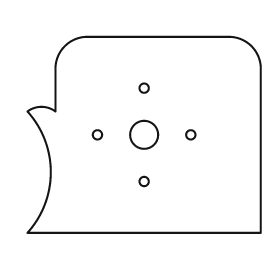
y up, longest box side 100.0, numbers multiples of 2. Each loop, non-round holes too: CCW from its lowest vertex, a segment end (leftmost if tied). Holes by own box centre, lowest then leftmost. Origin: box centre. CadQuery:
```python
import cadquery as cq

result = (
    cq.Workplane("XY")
    .moveTo(-50.0, -42.0)
    .lineTo(50.0, -42.0)
    .lineTo(50.0, 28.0)
    .threePointArc((46.0, 38.0), (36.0, 42.0))
    .lineTo(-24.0, 42.0)
    .threePointArc((-34.0, 38.0), (-38.0, 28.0))
    .lineTo(-38.0, 10.0)
    .threePointArc((-44.0, 12.0), (-50.0, 10.0))
    .threePointArc((-40.0, -16.0), (-50.0, -42.0))
    .close()
    .moveTo(0.0, -20.0)
    .circle(2.0)
    .moveTo(-20.0, 0.0)
    .circle(2.0)
    .moveTo(0.0, 0.0)
    .circle(6.0)
    .moveTo(20.0, 0.0)
    .circle(2.0)
    .moveTo(0.0, 20.0)
    .circle(2.0)
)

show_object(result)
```